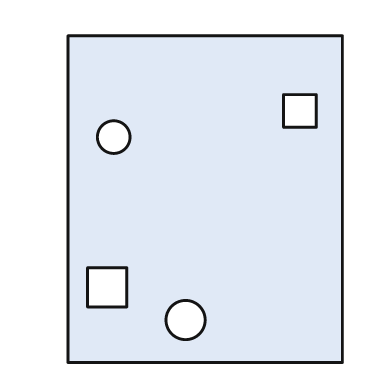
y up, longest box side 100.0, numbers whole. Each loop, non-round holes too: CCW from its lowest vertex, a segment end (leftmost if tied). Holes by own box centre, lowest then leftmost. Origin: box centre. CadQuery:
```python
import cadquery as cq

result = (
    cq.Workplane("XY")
    .moveTo(-42.0, -50.0)
    .lineTo(42.0, -50.0)
    .lineTo(42.0, 50.0)
    .lineTo(-42.0, 50.0)
    .close()
    .moveTo(-6.0, -37.0)
    .circle(6.0)
    .moveTo(-36.0, -33.0)
    .lineTo(-24.0, -33.0)
    .lineTo(-24.0, -21.0)
    .lineTo(-36.0, -21.0)
    .close()
    .moveTo(-28.0, 19.0)
    .circle(5.0)
    .moveTo(24.0, 22.0)
    .lineTo(34.0, 22.0)
    .lineTo(34.0, 32.0)
    .lineTo(24.0, 32.0)
    .close()
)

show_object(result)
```